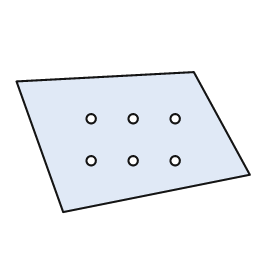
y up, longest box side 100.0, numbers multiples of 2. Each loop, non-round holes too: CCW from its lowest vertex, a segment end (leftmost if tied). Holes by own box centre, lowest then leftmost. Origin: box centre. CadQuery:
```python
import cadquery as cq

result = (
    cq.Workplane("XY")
    .moveTo(-30.0, -30.0)
    .lineTo(50.0, -14.0)
    .lineTo(26.0, 30.0)
    .lineTo(-50.0, 26.0)
    .close()
    .moveTo(-18.0, -8.0)
    .circle(2.0)
    .moveTo(0.0, -8.0)
    .circle(2.0)
    .moveTo(18.0, -8.0)
    .circle(2.0)
    .moveTo(-18.0, 10.0)
    .circle(2.0)
    .moveTo(0.0, 10.0)
    .circle(2.0)
    .moveTo(18.0, 10.0)
    .circle(2.0)
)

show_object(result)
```